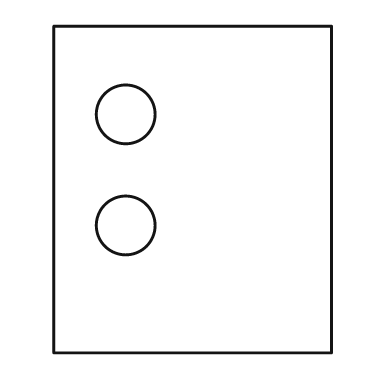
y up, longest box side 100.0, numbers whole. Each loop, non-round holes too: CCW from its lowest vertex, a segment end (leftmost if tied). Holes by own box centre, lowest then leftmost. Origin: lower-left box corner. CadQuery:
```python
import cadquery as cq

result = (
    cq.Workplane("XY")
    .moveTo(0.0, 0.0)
    .lineTo(85.0, 0.0)
    .lineTo(85.0, 100.0)
    .lineTo(0.0, 100.0)
    .close()
    .moveTo(22.0, 39.0)
    .circle(9.0)
    .moveTo(22.0, 73.0)
    .circle(9.0)
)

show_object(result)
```